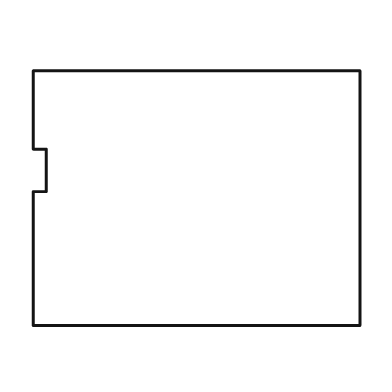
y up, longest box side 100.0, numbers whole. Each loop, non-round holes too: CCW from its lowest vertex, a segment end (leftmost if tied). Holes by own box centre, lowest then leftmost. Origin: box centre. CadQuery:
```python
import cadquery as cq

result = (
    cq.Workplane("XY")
    .moveTo(-50.0, -39.0)
    .lineTo(50.0, -39.0)
    .lineTo(50.0, 39.0)
    .lineTo(-50.0, 39.0)
    .lineTo(-50.0, 15.0)
    .lineTo(-46.0, 15.0)
    .lineTo(-46.0, 2.0)
    .lineTo(-50.0, 2.0)
    .close()
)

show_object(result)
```